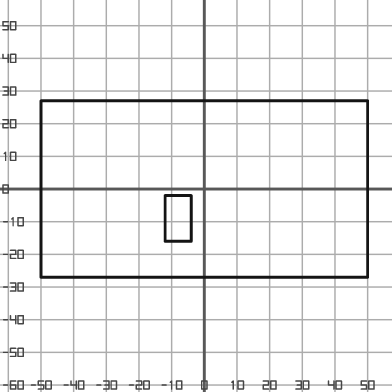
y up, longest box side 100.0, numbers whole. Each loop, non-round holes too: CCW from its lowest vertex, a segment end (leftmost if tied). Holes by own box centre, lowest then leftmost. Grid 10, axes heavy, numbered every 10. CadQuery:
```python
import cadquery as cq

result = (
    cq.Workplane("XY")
    .moveTo(-50.0, -27.0)
    .lineTo(50.0, -27.0)
    .lineTo(50.0, 27.0)
    .lineTo(-50.0, 27.0)
    .close()
    .moveTo(-12.0, -16.0)
    .lineTo(-4.0, -16.0)
    .lineTo(-4.0, -2.0)
    .lineTo(-12.0, -2.0)
    .close()
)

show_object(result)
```